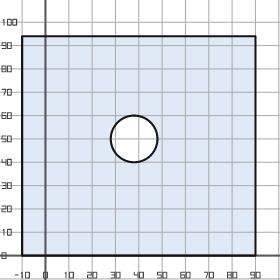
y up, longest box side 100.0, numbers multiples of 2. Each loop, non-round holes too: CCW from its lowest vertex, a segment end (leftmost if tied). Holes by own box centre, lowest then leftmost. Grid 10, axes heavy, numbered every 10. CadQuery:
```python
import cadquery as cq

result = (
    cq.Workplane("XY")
    .moveTo(-10.0, 0.0)
    .lineTo(90.0, 0.0)
    .lineTo(90.0, 94.0)
    .lineTo(-10.0, 94.0)
    .close()
    .moveTo(38.0, 50.0)
    .circle(10.0)
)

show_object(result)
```